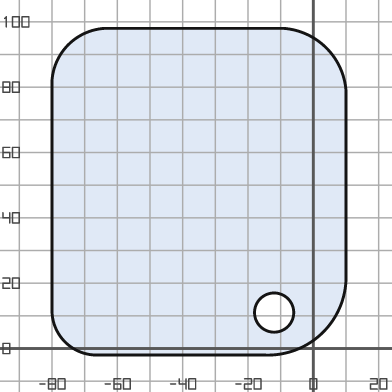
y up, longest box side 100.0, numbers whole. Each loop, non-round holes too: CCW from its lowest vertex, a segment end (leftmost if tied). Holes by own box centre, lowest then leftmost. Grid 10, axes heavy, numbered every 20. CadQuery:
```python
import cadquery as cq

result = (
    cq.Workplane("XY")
    .moveTo(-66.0, -2.0)
    .lineTo(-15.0, -2.0)
    .threePointArc((3.0, 5.0), (10.0, 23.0))
    .lineTo(10.0, 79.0)
    .threePointArc((4.0, 92.0), (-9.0, 98.0))
    .lineTo(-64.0, 98.0)
    .threePointArc((-75.0, 93.0), (-80.0, 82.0))
    .lineTo(-80.0, 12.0)
    .threePointArc((-76.0, 2.0), (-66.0, -2.0))
    .close()
    .moveTo(-12.0, 11.0)
    .circle(6.0)
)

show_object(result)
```